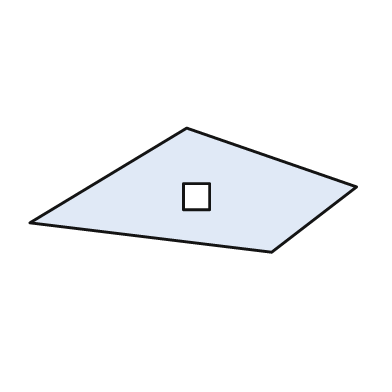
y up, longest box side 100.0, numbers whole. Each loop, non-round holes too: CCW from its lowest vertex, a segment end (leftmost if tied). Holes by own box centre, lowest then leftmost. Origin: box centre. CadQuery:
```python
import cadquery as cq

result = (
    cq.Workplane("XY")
    .moveTo(24.0, -19.0)
    .lineTo(50.0, 1.0)
    .lineTo(-2.0, 19.0)
    .lineTo(-50.0, -10.0)
    .close()
    .moveTo(-3.0, -6.0)
    .lineTo(5.0, -6.0)
    .lineTo(5.0, 2.0)
    .lineTo(-3.0, 2.0)
    .close()
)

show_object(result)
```